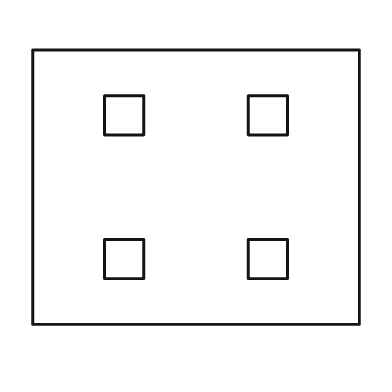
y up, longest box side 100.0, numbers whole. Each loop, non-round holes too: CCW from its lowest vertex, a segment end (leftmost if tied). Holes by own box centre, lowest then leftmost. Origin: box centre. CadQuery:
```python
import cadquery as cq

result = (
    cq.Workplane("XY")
    .moveTo(-50.0, -42.0)
    .lineTo(50.0, -42.0)
    .lineTo(50.0, 42.0)
    .lineTo(-50.0, 42.0)
    .close()
    .moveTo(-28.0, -28.0)
    .lineTo(-16.0, -28.0)
    .lineTo(-16.0, -16.0)
    .lineTo(-28.0, -16.0)
    .close()
    .moveTo(16.0, -28.0)
    .lineTo(28.0, -28.0)
    .lineTo(28.0, -16.0)
    .lineTo(16.0, -16.0)
    .close()
    .moveTo(-28.0, 16.0)
    .lineTo(-16.0, 16.0)
    .lineTo(-16.0, 28.0)
    .lineTo(-28.0, 28.0)
    .close()
    .moveTo(16.0, 16.0)
    .lineTo(28.0, 16.0)
    .lineTo(28.0, 28.0)
    .lineTo(16.0, 28.0)
    .close()
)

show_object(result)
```